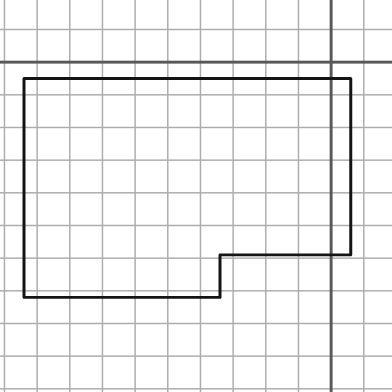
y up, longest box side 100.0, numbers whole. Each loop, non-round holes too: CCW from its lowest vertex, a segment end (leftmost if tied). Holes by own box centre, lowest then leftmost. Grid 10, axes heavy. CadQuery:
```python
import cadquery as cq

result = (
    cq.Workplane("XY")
    .moveTo(-94.0, -72.0)
    .lineTo(-34.0, -72.0)
    .lineTo(-34.0, -59.0)
    .lineTo(6.0, -59.0)
    .lineTo(6.0, -5.0)
    .lineTo(-94.0, -5.0)
    .close()
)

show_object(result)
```